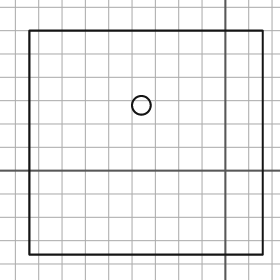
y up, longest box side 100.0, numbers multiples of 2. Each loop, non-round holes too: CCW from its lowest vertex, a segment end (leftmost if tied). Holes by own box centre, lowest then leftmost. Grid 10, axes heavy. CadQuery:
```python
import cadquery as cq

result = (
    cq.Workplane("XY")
    .moveTo(-84.0, -36.0)
    .lineTo(16.0, -36.0)
    .lineTo(16.0, 60.0)
    .lineTo(-84.0, 60.0)
    .close()
    .moveTo(-36.0, 28.0)
    .circle(4.0)
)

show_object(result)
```